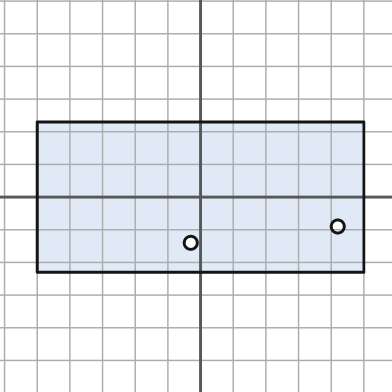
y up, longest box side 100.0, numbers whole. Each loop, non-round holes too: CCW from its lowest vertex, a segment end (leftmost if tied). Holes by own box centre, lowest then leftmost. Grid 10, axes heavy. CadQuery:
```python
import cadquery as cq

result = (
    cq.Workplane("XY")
    .moveTo(-50.0, -23.0)
    .lineTo(50.0, -23.0)
    .lineTo(50.0, 23.0)
    .lineTo(-50.0, 23.0)
    .close()
    .moveTo(-3.0, -14.0)
    .circle(2.0)
    .moveTo(42.0, -9.0)
    .circle(2.0)
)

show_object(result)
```